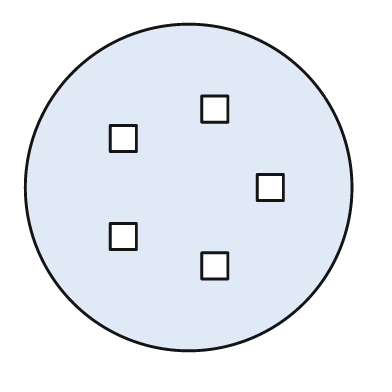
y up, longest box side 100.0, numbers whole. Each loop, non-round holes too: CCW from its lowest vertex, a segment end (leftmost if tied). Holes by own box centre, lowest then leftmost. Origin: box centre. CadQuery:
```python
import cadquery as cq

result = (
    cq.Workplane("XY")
    .moveTo(0.0, 0.0)
    .circle(50.0)
    .moveTo(4.0, -28.0)
    .lineTo(12.0, -28.0)
    .lineTo(12.0, -20.0)
    .lineTo(4.0, -20.0)
    .close()
    .moveTo(-24.0, -19.0)
    .lineTo(-16.0, -19.0)
    .lineTo(-16.0, -11.0)
    .lineTo(-24.0, -11.0)
    .close()
    .moveTo(21.0, -4.0)
    .lineTo(29.0, -4.0)
    .lineTo(29.0, 4.0)
    .lineTo(21.0, 4.0)
    .close()
    .moveTo(-24.0, 11.0)
    .lineTo(-16.0, 11.0)
    .lineTo(-16.0, 19.0)
    .lineTo(-24.0, 19.0)
    .close()
    .moveTo(4.0, 20.0)
    .lineTo(12.0, 20.0)
    .lineTo(12.0, 28.0)
    .lineTo(4.0, 28.0)
    .close()
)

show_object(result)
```